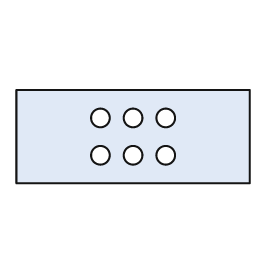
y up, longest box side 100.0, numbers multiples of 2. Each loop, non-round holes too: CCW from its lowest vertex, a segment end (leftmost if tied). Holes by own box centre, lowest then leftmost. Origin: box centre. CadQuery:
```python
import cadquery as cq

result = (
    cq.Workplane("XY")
    .moveTo(-50.0, -20.0)
    .lineTo(50.0, -20.0)
    .lineTo(50.0, 20.0)
    .lineTo(-50.0, 20.0)
    .close()
    .moveTo(-14.0, -8.0)
    .circle(4.0)
    .moveTo(0.0, -8.0)
    .circle(4.0)
    .moveTo(14.0, -8.0)
    .circle(4.0)
    .moveTo(-14.0, 8.0)
    .circle(4.0)
    .moveTo(0.0, 8.0)
    .circle(4.0)
    .moveTo(14.0, 8.0)
    .circle(4.0)
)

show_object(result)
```